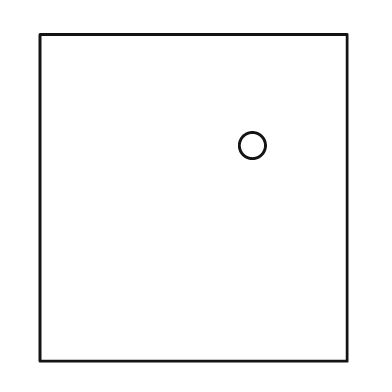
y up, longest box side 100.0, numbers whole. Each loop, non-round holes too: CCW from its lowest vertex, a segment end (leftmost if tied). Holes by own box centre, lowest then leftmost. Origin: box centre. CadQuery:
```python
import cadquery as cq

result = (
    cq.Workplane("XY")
    .moveTo(-47.0, -50.0)
    .lineTo(47.0, -50.0)
    .lineTo(47.0, 50.0)
    .lineTo(-47.0, 50.0)
    .close()
    .moveTo(18.0, 16.0)
    .circle(4.0)
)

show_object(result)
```